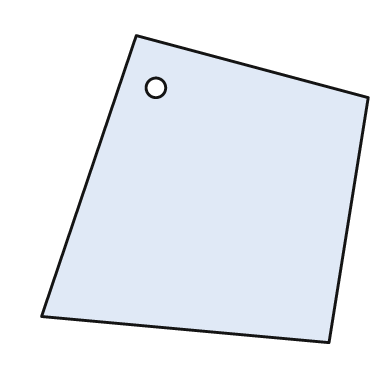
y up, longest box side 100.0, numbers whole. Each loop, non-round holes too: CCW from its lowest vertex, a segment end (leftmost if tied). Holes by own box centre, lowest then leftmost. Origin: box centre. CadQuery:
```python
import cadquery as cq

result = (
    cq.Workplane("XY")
    .moveTo(38.0, -47.0)
    .lineTo(50.0, 28.0)
    .lineTo(-21.0, 47.0)
    .lineTo(-50.0, -39.0)
    .close()
    .moveTo(-15.0, 31.0)
    .circle(3.0)
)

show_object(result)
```